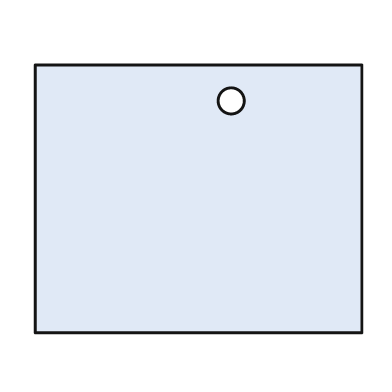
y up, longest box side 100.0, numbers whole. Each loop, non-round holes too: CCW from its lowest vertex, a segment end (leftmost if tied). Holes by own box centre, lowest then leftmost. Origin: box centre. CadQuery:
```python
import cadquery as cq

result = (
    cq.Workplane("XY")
    .moveTo(-50.0, -41.0)
    .lineTo(50.0, -41.0)
    .lineTo(50.0, 41.0)
    .lineTo(-50.0, 41.0)
    .close()
    .moveTo(10.0, 30.0)
    .circle(4.0)
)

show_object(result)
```